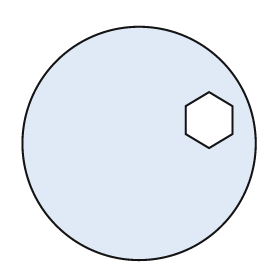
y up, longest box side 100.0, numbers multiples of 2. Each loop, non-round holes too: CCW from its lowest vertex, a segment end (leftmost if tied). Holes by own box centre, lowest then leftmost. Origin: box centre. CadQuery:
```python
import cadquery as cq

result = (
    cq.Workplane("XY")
    .moveTo(0.0, 0.0)
    .circle(50.0)
    .moveTo(30.0, -2.0)
    .lineTo(40.0, 4.0)
    .lineTo(40.0, 16.0)
    .lineTo(30.0, 22.0)
    .lineTo(20.0, 16.0)
    .lineTo(20.0, 4.0)
    .close()
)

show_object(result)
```